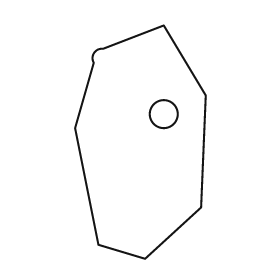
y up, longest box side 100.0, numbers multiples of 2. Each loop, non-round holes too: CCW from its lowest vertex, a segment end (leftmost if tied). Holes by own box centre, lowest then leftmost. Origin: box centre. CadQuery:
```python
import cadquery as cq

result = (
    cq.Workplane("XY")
    .moveTo(2.0, -50.0)
    .lineTo(26.0, -28.0)
    .lineTo(28.0, 20.0)
    .lineTo(10.0, 50.0)
    .lineTo(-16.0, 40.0)
    .threePointArc((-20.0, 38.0), (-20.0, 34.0))
    .lineTo(-28.0, 6.0)
    .lineTo(-18.0, -44.0)
    .close()
    .moveTo(10.0, 12.0)
    .circle(6.0)
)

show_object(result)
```